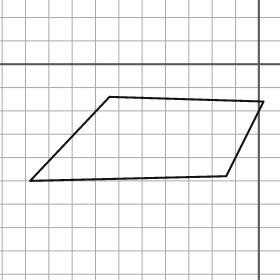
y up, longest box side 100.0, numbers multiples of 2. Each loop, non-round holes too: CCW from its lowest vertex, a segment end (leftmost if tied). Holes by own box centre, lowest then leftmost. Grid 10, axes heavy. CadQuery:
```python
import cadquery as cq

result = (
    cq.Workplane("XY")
    .moveTo(-98.0, -50.0)
    .lineTo(-14.0, -48.0)
    .lineTo(2.0, -16.0)
    .lineTo(-64.0, -14.0)
    .close()
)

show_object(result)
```